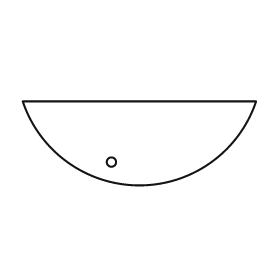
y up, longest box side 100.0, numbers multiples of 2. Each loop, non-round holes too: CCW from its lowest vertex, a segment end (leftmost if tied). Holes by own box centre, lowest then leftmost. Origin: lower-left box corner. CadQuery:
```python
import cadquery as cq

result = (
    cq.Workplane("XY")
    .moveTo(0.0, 36.0)
    .threePointArc((50.0, 0.0), (100.0, 36.0))
    .close()
    .moveTo(38.0, 10.0)
    .circle(2.0)
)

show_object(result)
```